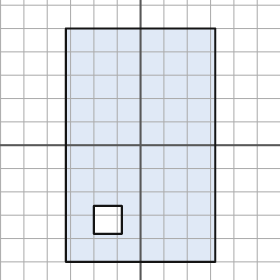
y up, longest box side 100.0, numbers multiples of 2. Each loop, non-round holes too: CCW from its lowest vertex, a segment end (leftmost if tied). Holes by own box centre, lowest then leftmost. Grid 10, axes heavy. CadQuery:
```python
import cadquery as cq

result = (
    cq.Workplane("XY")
    .moveTo(-32.0, -50.0)
    .lineTo(32.0, -50.0)
    .lineTo(32.0, 50.0)
    .lineTo(-32.0, 50.0)
    .close()
    .moveTo(-20.0, -38.0)
    .lineTo(-8.0, -38.0)
    .lineTo(-8.0, -26.0)
    .lineTo(-20.0, -26.0)
    .close()
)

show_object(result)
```